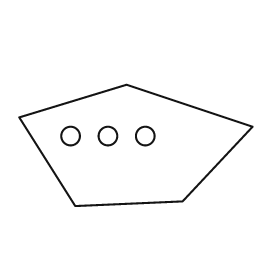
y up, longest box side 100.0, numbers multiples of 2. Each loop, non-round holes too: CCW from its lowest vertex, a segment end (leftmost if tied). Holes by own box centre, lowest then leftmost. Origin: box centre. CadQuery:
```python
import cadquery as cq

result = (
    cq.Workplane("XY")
    .moveTo(-26.0, -26.0)
    .lineTo(20.0, -24.0)
    .lineTo(50.0, 8.0)
    .lineTo(-4.0, 26.0)
    .lineTo(-50.0, 12.0)
    .close()
    .moveTo(-28.0, 4.0)
    .circle(4.0)
    .moveTo(-12.0, 4.0)
    .circle(4.0)
    .moveTo(4.0, 4.0)
    .circle(4.0)
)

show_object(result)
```